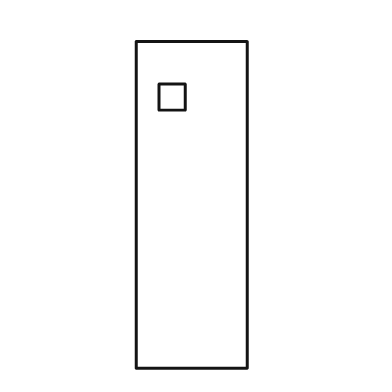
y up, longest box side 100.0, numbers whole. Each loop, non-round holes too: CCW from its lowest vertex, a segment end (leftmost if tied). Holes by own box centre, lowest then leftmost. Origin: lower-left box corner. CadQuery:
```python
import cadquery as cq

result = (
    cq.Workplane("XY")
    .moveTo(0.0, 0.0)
    .lineTo(34.0, 0.0)
    .lineTo(34.0, 100.0)
    .lineTo(0.0, 100.0)
    .close()
    .moveTo(7.0, 79.0)
    .lineTo(15.0, 79.0)
    .lineTo(15.0, 87.0)
    .lineTo(7.0, 87.0)
    .close()
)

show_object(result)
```